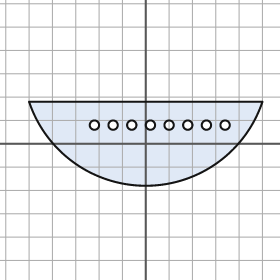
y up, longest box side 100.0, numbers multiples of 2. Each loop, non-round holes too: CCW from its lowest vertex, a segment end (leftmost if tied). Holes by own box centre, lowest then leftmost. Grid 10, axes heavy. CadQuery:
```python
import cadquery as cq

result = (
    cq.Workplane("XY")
    .moveTo(-50.0, 18.0)
    .threePointArc((0.0, -18.0), (50.0, 18.0))
    .close()
    .moveTo(-22.0, 8.0)
    .circle(2.0)
    .moveTo(-14.0, 8.0)
    .circle(2.0)
    .moveTo(-6.0, 8.0)
    .circle(2.0)
    .moveTo(2.0, 8.0)
    .circle(2.0)
    .moveTo(10.0, 8.0)
    .circle(2.0)
    .moveTo(18.0, 8.0)
    .circle(2.0)
    .moveTo(26.0, 8.0)
    .circle(2.0)
    .moveTo(34.0, 8.0)
    .circle(2.0)
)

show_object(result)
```